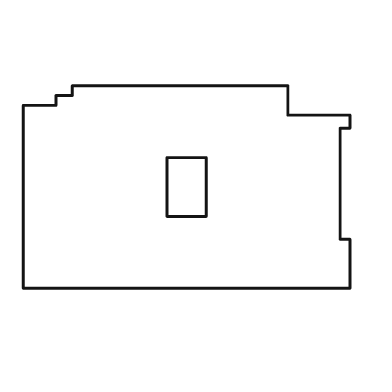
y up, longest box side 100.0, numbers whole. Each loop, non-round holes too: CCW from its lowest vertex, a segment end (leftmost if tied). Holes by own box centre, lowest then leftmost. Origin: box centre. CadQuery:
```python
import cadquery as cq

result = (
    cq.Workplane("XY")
    .moveTo(-50.0, -31.0)
    .lineTo(50.0, -31.0)
    .lineTo(50.0, -16.0)
    .lineTo(47.0, -16.0)
    .lineTo(47.0, 18.0)
    .lineTo(50.0, 18.0)
    .lineTo(50.0, 22.0)
    .lineTo(31.0, 22.0)
    .lineTo(31.0, 31.0)
    .lineTo(-35.0, 31.0)
    .lineTo(-35.0, 28.0)
    .lineTo(-40.0, 28.0)
    .lineTo(-40.0, 25.0)
    .lineTo(-50.0, 25.0)
    .close()
    .moveTo(-6.0, -9.0)
    .lineTo(6.0, -9.0)
    .lineTo(6.0, 9.0)
    .lineTo(-6.0, 9.0)
    .close()
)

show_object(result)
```